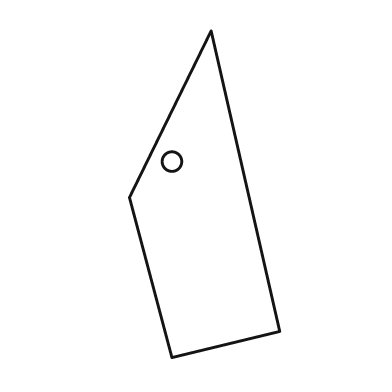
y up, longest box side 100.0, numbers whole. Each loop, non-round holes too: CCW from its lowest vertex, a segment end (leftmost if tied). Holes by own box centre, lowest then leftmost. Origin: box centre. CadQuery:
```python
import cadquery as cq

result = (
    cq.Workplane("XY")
    .moveTo(-10.0, -50.0)
    .lineTo(23.0, -42.0)
    .lineTo(2.0, 50.0)
    .lineTo(-23.0, -1.0)
    .close()
    .moveTo(-10.0, 10.0)
    .circle(3.0)
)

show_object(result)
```